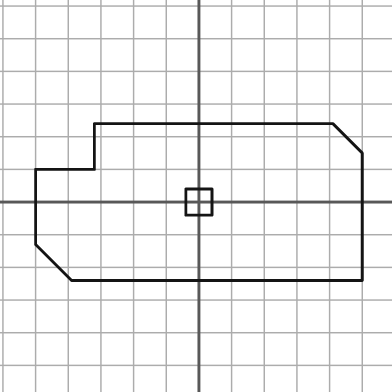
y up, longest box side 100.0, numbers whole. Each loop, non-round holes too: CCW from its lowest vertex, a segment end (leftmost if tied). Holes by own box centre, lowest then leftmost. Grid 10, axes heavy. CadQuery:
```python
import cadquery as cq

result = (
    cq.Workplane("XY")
    .moveTo(-39.0, -24.0)
    .lineTo(50.0, -24.0)
    .lineTo(50.0, 15.0)
    .lineTo(41.0, 24.0)
    .lineTo(-32.0, 24.0)
    .lineTo(-32.0, 10.0)
    .lineTo(-50.0, 10.0)
    .lineTo(-50.0, -13.0)
    .close()
    .moveTo(-4.0, -4.0)
    .lineTo(4.0, -4.0)
    .lineTo(4.0, 4.0)
    .lineTo(-4.0, 4.0)
    .close()
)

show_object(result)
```